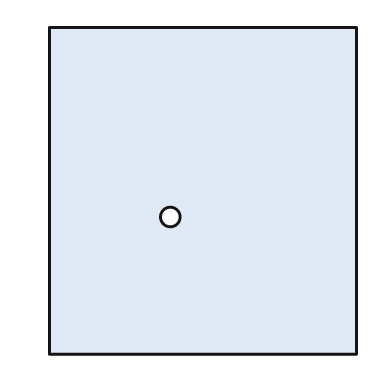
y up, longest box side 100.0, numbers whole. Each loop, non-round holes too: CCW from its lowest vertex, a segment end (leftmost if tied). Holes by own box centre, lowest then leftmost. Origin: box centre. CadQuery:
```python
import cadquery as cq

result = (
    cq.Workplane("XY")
    .moveTo(-47.0, -50.0)
    .lineTo(47.0, -50.0)
    .lineTo(47.0, 50.0)
    .lineTo(-47.0, 50.0)
    .close()
    .moveTo(-10.0, -8.0)
    .circle(3.0)
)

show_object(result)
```